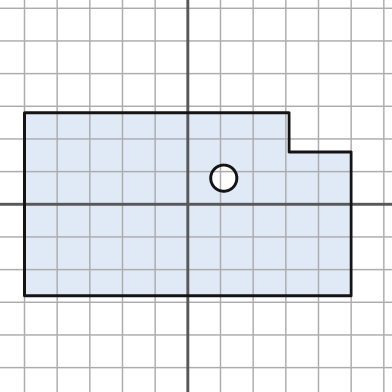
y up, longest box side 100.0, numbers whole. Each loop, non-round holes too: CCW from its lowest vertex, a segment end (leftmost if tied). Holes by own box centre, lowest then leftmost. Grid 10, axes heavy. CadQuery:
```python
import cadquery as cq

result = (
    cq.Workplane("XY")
    .moveTo(-50.0, -28.0)
    .lineTo(50.0, -28.0)
    .lineTo(50.0, 16.0)
    .lineTo(31.0, 16.0)
    .lineTo(31.0, 28.0)
    .lineTo(-50.0, 28.0)
    .close()
    .moveTo(11.0, 8.0)
    .circle(4.0)
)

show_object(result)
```